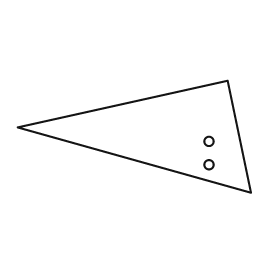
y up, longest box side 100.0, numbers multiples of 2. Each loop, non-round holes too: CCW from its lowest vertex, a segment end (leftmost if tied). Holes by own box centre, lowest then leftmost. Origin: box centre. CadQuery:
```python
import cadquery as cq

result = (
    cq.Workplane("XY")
    .moveTo(50.0, -24.0)
    .lineTo(40.0, 24.0)
    .lineTo(-50.0, 4.0)
    .close()
    .moveTo(32.0, -12.0)
    .circle(2.0)
    .moveTo(32.0, -2.0)
    .circle(2.0)
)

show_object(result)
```